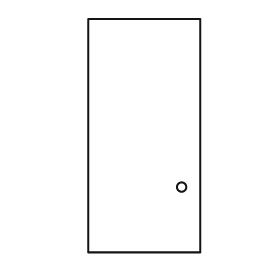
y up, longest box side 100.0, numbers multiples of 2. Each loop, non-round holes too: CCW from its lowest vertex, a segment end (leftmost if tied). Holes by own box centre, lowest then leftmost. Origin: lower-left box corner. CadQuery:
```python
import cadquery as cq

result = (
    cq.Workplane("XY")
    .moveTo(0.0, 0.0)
    .lineTo(48.0, 0.0)
    .lineTo(48.0, 100.0)
    .lineTo(0.0, 100.0)
    .close()
    .moveTo(40.0, 28.0)
    .circle(2.0)
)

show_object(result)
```